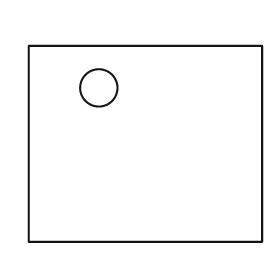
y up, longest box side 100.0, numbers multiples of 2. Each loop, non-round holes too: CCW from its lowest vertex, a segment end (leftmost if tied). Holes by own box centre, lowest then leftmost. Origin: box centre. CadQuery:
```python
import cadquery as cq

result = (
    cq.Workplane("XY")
    .moveTo(-50.0, -42.0)
    .lineTo(50.0, -42.0)
    .lineTo(50.0, 42.0)
    .lineTo(-50.0, 42.0)
    .close()
    .moveTo(-20.0, 24.0)
    .circle(8.0)
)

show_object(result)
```